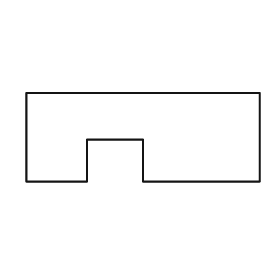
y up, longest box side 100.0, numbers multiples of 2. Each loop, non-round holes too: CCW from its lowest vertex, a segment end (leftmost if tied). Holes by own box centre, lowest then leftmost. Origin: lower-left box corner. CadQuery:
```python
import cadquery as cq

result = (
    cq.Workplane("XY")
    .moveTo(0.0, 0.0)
    .lineTo(26.0, 0.0)
    .lineTo(26.0, 18.0)
    .lineTo(50.0, 18.0)
    .lineTo(50.0, 0.0)
    .lineTo(100.0, 0.0)
    .lineTo(100.0, 38.0)
    .lineTo(0.0, 38.0)
    .close()
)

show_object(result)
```